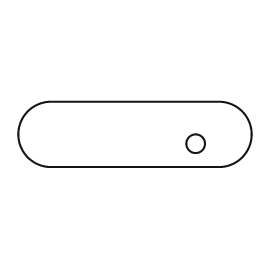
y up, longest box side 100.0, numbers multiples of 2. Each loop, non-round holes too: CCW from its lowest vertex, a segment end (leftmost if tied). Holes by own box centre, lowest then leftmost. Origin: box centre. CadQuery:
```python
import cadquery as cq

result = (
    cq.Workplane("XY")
    .moveTo(-36.0, -14.0)
    .lineTo(36.0, -14.0)
    .threePointArc((50.0, 0.0), (36.0, 14.0))
    .lineTo(-36.0, 14.0)
    .threePointArc((-50.0, 0.0), (-36.0, -14.0))
    .close()
    .moveTo(26.0, -4.0)
    .circle(4.0)
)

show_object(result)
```